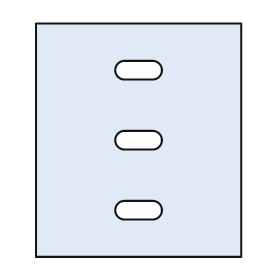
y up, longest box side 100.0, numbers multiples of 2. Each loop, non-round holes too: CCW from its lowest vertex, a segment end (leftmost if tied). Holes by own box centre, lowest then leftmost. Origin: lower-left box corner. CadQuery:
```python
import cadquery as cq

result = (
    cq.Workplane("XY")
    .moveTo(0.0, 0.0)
    .lineTo(88.0, 0.0)
    .lineTo(88.0, 100.0)
    .lineTo(0.0, 100.0)
    .close()
    .moveTo(38.0, 16.0)
    .lineTo(50.0, 16.0)
    .threePointArc((54.0, 20.0), (50.0, 24.0))
    .lineTo(38.0, 24.0)
    .threePointArc((34.0, 20.0), (38.0, 16.0))
    .close()
    .moveTo(38.0, 46.0)
    .lineTo(50.0, 46.0)
    .threePointArc((54.0, 50.0), (50.0, 54.0))
    .lineTo(38.0, 54.0)
    .threePointArc((34.0, 50.0), (38.0, 46.0))
    .close()
    .moveTo(38.0, 76.0)
    .lineTo(50.0, 76.0)
    .threePointArc((54.0, 80.0), (50.0, 84.0))
    .lineTo(38.0, 84.0)
    .threePointArc((34.0, 80.0), (38.0, 76.0))
    .close()
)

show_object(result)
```